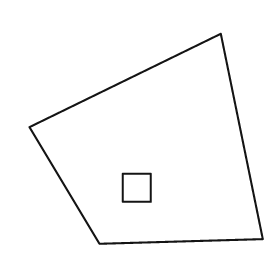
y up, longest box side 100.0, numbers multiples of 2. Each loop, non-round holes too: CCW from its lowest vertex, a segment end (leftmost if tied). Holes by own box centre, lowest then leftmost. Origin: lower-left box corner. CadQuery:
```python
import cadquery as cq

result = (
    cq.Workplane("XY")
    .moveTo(30.0, 0.0)
    .lineTo(100.0, 2.0)
    .lineTo(82.0, 90.0)
    .lineTo(0.0, 50.0)
    .close()
    .moveTo(40.0, 18.0)
    .lineTo(52.0, 18.0)
    .lineTo(52.0, 30.0)
    .lineTo(40.0, 30.0)
    .close()
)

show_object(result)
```